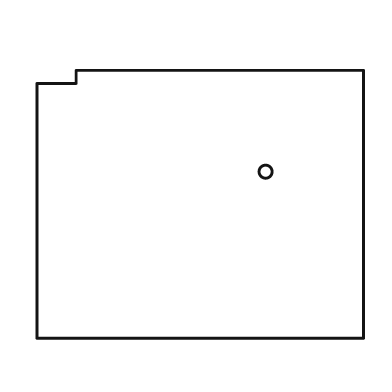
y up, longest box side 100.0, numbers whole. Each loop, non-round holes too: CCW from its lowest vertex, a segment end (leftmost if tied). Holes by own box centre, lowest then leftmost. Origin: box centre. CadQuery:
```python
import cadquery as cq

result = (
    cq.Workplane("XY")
    .moveTo(-50.0, -41.0)
    .lineTo(50.0, -41.0)
    .lineTo(50.0, 41.0)
    .lineTo(-38.0, 41.0)
    .lineTo(-38.0, 37.0)
    .lineTo(-50.0, 37.0)
    .close()
    .moveTo(20.0, 10.0)
    .circle(2.0)
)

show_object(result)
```